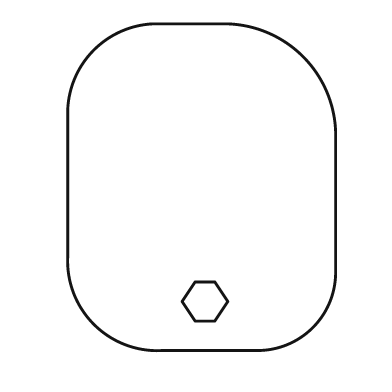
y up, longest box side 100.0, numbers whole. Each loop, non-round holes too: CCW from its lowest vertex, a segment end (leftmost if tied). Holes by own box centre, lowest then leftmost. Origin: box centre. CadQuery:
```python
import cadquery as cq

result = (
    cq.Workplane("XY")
    .moveTo(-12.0, -50.0)
    .lineTo(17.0, -50.0)
    .threePointArc((34.0, -43.0), (41.0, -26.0))
    .lineTo(41.0, 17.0)
    .threePointArc((31.0, 40.0), (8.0, 50.0))
    .lineTo(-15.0, 50.0)
    .threePointArc((-33.0, 42.0), (-41.0, 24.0))
    .lineTo(-41.0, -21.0)
    .threePointArc((-33.0, -42.0), (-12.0, -50.0))
    .close()
    .moveTo(-2.0, -41.0)
    .lineTo(4.0, -41.0)
    .lineTo(8.0, -35.0)
    .lineTo(4.0, -29.0)
    .lineTo(-2.0, -29.0)
    .lineTo(-6.0, -35.0)
    .close()
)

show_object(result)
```